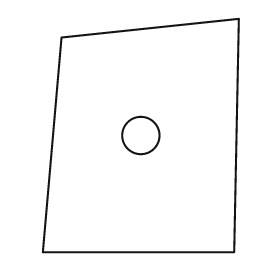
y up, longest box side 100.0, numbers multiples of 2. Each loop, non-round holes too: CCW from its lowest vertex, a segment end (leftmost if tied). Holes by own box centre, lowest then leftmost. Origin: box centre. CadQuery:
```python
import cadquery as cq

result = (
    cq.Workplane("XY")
    .moveTo(-42.0, -50.0)
    .lineTo(40.0, -50.0)
    .lineTo(42.0, 50.0)
    .lineTo(-34.0, 42.0)
    .close()
    .moveTo(0.0, 0.0)
    .circle(8.0)
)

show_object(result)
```